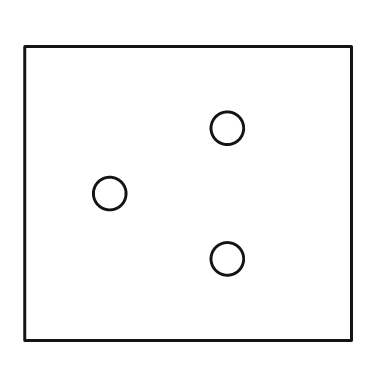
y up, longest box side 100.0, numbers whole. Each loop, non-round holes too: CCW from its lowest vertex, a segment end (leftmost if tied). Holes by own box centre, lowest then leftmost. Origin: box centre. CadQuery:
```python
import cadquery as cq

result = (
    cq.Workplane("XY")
    .moveTo(-50.0, -45.0)
    .lineTo(50.0, -45.0)
    .lineTo(50.0, 45.0)
    .lineTo(-50.0, 45.0)
    .close()
    .moveTo(12.0, -20.0)
    .circle(5.0)
    .moveTo(-24.0, 0.0)
    .circle(5.0)
    .moveTo(12.0, 20.0)
    .circle(5.0)
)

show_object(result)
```